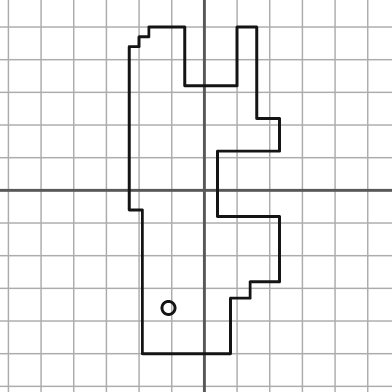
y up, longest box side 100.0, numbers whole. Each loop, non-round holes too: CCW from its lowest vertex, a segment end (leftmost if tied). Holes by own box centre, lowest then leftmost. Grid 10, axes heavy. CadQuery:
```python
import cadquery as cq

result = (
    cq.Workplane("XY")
    .moveTo(-19.0, -50.0)
    .lineTo(8.0, -50.0)
    .lineTo(8.0, -33.0)
    .lineTo(14.0, -33.0)
    .lineTo(14.0, -28.0)
    .lineTo(23.0, -28.0)
    .lineTo(23.0, -8.0)
    .lineTo(4.0, -8.0)
    .lineTo(4.0, 12.0)
    .lineTo(23.0, 12.0)
    .lineTo(23.0, 22.0)
    .lineTo(16.0, 22.0)
    .lineTo(16.0, 50.0)
    .lineTo(10.0, 50.0)
    .lineTo(10.0, 32.0)
    .lineTo(-6.0, 32.0)
    .lineTo(-6.0, 50.0)
    .lineTo(-17.0, 50.0)
    .lineTo(-17.0, 47.0)
    .lineTo(-20.0, 47.0)
    .lineTo(-20.0, 44.0)
    .lineTo(-23.0, 44.0)
    .lineTo(-23.0, -6.0)
    .lineTo(-19.0, -6.0)
    .close()
    .moveTo(-11.0, -36.0)
    .circle(2.0)
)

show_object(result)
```